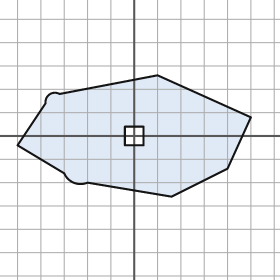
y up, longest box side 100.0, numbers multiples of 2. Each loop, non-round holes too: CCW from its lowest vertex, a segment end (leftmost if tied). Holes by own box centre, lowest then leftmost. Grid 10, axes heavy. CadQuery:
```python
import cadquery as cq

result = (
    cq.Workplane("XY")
    .moveTo(16.0, -26.0)
    .lineTo(40.0, -14.0)
    .lineTo(50.0, 8.0)
    .lineTo(10.0, 26.0)
    .lineTo(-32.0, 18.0)
    .threePointArc((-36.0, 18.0), (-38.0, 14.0))
    .lineTo(-50.0, -4.0)
    .lineTo(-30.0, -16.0)
    .threePointArc((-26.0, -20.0), (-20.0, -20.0))
    .close()
    .moveTo(-4.0, -4.0)
    .lineTo(4.0, -4.0)
    .lineTo(4.0, 4.0)
    .lineTo(-4.0, 4.0)
    .close()
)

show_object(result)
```